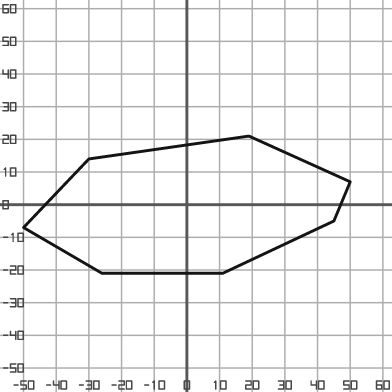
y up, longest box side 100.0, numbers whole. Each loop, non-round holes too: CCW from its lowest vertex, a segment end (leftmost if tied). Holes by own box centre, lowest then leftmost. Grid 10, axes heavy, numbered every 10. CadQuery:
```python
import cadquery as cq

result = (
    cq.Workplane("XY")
    .moveTo(-26.0, -21.0)
    .lineTo(11.0, -21.0)
    .lineTo(45.0, -5.0)
    .lineTo(50.0, 7.0)
    .lineTo(19.0, 21.0)
    .lineTo(-30.0, 14.0)
    .lineTo(-50.0, -7.0)
    .close()
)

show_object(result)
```